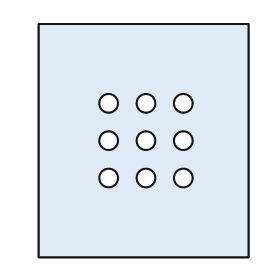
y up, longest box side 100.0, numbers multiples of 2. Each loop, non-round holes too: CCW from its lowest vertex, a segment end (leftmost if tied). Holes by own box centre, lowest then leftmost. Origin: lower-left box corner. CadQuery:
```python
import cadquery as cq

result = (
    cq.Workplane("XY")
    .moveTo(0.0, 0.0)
    .lineTo(90.0, 0.0)
    .lineTo(90.0, 100.0)
    .lineTo(0.0, 100.0)
    .close()
    .moveTo(30.0, 34.0)
    .circle(4.0)
    .moveTo(46.0, 34.0)
    .circle(4.0)
    .moveTo(62.0, 34.0)
    .circle(4.0)
    .moveTo(30.0, 50.0)
    .circle(4.0)
    .moveTo(46.0, 50.0)
    .circle(4.0)
    .moveTo(62.0, 50.0)
    .circle(4.0)
    .moveTo(30.0, 66.0)
    .circle(4.0)
    .moveTo(46.0, 66.0)
    .circle(4.0)
    .moveTo(62.0, 66.0)
    .circle(4.0)
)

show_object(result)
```